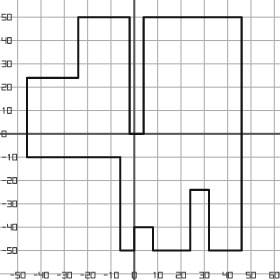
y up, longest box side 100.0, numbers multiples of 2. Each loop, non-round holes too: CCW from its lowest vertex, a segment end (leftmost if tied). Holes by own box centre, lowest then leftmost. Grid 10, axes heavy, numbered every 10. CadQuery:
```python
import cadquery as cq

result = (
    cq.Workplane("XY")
    .moveTo(-6.0, -50.0)
    .lineTo(0.0, -50.0)
    .lineTo(0.0, -40.0)
    .lineTo(8.0, -40.0)
    .lineTo(8.0, -50.0)
    .lineTo(24.0, -50.0)
    .lineTo(24.0, -24.0)
    .lineTo(32.0, -24.0)
    .lineTo(32.0, -50.0)
    .lineTo(46.0, -50.0)
    .lineTo(46.0, 50.0)
    .lineTo(4.0, 50.0)
    .lineTo(4.0, 0.0)
    .lineTo(-2.0, 0.0)
    .lineTo(-2.0, 50.0)
    .lineTo(-24.0, 50.0)
    .lineTo(-24.0, 24.0)
    .lineTo(-46.0, 24.0)
    .lineTo(-46.0, -10.0)
    .lineTo(-6.0, -10.0)
    .close()
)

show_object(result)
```